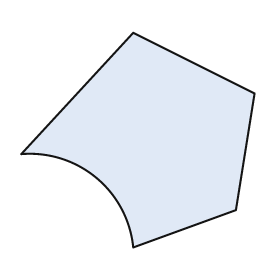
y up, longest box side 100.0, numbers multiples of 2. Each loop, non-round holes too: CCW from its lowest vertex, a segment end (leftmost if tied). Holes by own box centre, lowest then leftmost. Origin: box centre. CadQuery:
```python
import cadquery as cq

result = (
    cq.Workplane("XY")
    .moveTo(-2.0, -46.0)
    .lineTo(42.0, -30.0)
    .lineTo(50.0, 20.0)
    .lineTo(-2.0, 46.0)
    .lineTo(-50.0, -6.0)
    .threePointArc((-18.0, -16.0), (-2.0, -46.0))
    .close()
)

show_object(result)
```